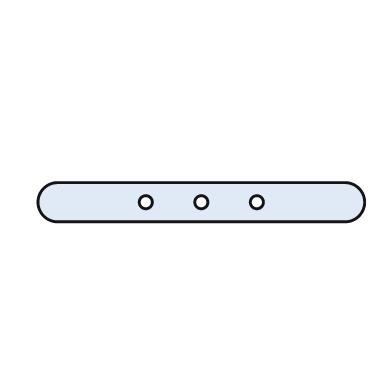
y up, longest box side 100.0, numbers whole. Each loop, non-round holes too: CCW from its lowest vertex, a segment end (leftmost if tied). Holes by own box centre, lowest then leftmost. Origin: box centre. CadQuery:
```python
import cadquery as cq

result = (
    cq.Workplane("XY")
    .moveTo(-44.0, -6.0)
    .lineTo(44.0, -6.0)
    .threePointArc((50.0, 0.0), (44.0, 6.0))
    .lineTo(-44.0, 6.0)
    .threePointArc((-50.0, 0.0), (-44.0, -6.0))
    .close()
    .moveTo(-17.0, 0.0)
    .circle(2.0)
    .moveTo(0.0, 0.0)
    .circle(2.0)
    .moveTo(17.0, 0.0)
    .circle(2.0)
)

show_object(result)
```